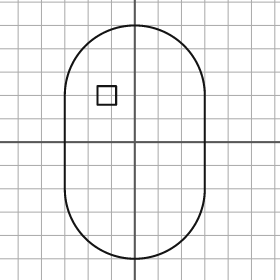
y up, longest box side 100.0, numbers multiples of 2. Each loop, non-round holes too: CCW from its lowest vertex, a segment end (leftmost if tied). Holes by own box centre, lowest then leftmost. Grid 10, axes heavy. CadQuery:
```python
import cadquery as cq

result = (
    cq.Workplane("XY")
    .moveTo(-30.0, -20.0)
    .threePointArc((0.0, -50.0), (30.0, -20.0))
    .lineTo(30.0, 20.0)
    .threePointArc((0.0, 50.0), (-30.0, 20.0))
    .close()
    .moveTo(-16.0, 16.0)
    .lineTo(-8.0, 16.0)
    .lineTo(-8.0, 24.0)
    .lineTo(-16.0, 24.0)
    .close()
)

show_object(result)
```